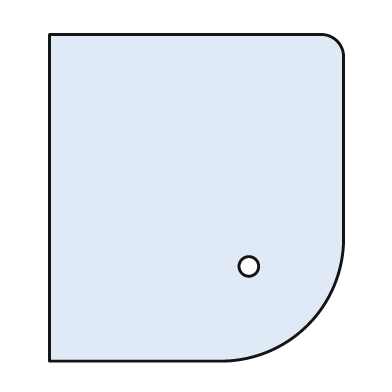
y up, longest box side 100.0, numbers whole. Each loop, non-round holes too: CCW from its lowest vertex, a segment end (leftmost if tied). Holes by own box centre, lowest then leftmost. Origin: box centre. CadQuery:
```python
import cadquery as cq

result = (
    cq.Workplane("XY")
    .moveTo(-45.0, -50.0)
    .lineTo(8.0, -50.0)
    .threePointArc((34.0, -39.0), (45.0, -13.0))
    .lineTo(45.0, 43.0)
    .threePointArc((43.0, 48.0), (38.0, 50.0))
    .lineTo(-45.0, 50.0)
    .close()
    .moveTo(16.0, -21.0)
    .circle(3.0)
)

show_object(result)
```